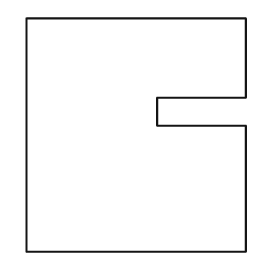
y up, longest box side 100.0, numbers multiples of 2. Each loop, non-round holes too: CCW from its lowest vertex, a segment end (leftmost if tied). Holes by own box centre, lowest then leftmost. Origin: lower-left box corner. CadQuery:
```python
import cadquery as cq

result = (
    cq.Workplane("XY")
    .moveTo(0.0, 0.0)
    .lineTo(94.0, 0.0)
    .lineTo(94.0, 54.0)
    .lineTo(56.0, 54.0)
    .lineTo(56.0, 66.0)
    .lineTo(94.0, 66.0)
    .lineTo(94.0, 100.0)
    .lineTo(0.0, 100.0)
    .close()
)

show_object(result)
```